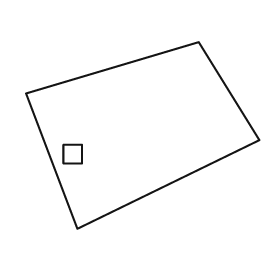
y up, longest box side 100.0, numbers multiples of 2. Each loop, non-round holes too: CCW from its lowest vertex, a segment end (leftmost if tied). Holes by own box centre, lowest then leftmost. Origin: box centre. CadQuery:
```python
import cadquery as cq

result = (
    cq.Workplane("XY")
    .moveTo(-28.0, -40.0)
    .lineTo(50.0, -2.0)
    .lineTo(24.0, 40.0)
    .lineTo(-50.0, 18.0)
    .close()
    .moveTo(-34.0, -12.0)
    .lineTo(-26.0, -12.0)
    .lineTo(-26.0, -4.0)
    .lineTo(-34.0, -4.0)
    .close()
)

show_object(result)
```